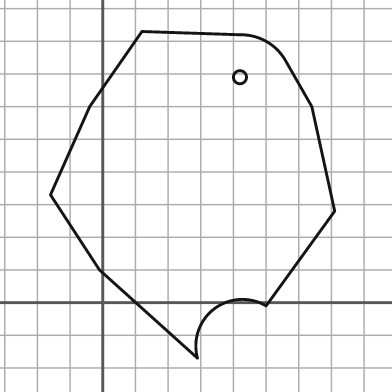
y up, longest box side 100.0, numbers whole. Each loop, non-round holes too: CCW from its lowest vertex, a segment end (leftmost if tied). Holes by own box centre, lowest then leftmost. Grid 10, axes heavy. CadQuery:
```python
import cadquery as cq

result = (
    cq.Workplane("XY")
    .moveTo(29.0, -17.0)
    .threePointArc((34.0, -2.0), (50.0, -1.0))
    .lineTo(71.0, 28.0)
    .lineTo(64.0, 60.0)
    .lineTo(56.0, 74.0)
    .threePointArc((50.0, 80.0), (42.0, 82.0))
    .lineTo(12.0, 83.0)
    .lineTo(-4.0, 60.0)
    .lineTo(-16.0, 33.0)
    .lineTo(-1.0, 10.0)
    .close()
    .moveTo(42.0, 69.0)
    .circle(2.0)
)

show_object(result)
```